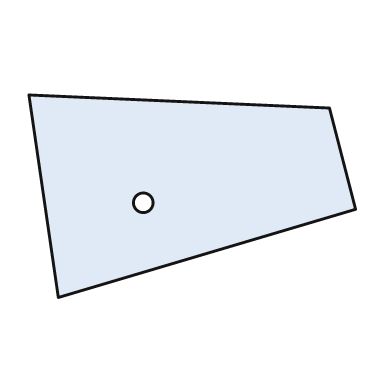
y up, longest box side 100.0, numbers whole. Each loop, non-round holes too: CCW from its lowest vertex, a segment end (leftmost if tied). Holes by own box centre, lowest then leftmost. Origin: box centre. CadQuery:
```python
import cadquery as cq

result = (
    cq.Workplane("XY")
    .moveTo(-41.0, -31.0)
    .lineTo(50.0, -4.0)
    .lineTo(42.0, 27.0)
    .lineTo(-50.0, 31.0)
    .close()
    .moveTo(-15.0, -2.0)
    .circle(3.0)
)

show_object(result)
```